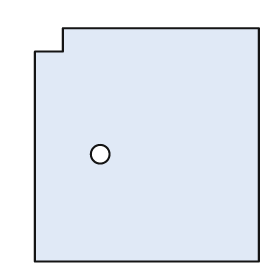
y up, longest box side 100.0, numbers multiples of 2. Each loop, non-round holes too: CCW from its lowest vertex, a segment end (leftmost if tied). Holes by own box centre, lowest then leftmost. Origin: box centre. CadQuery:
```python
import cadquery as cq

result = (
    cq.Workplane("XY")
    .moveTo(-48.0, -50.0)
    .lineTo(48.0, -50.0)
    .lineTo(48.0, 50.0)
    .lineTo(-36.0, 50.0)
    .lineTo(-36.0, 40.0)
    .lineTo(-48.0, 40.0)
    .close()
    .moveTo(-20.0, -4.0)
    .circle(4.0)
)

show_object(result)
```